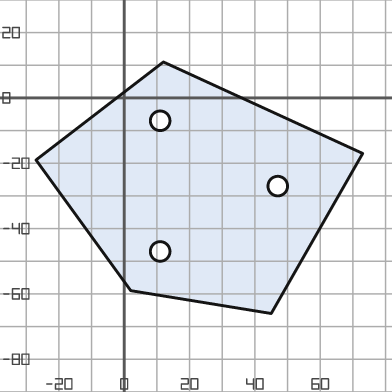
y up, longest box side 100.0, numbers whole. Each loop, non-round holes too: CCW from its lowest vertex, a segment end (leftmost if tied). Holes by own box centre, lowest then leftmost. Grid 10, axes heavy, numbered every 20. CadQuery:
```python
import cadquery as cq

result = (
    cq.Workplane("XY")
    .moveTo(45.0, -66.0)
    .lineTo(73.0, -17.0)
    .lineTo(12.0, 11.0)
    .lineTo(-27.0, -19.0)
    .lineTo(2.0, -59.0)
    .close()
    .moveTo(11.0, -47.0)
    .circle(3.0)
    .moveTo(47.0, -27.0)
    .circle(3.0)
    .moveTo(11.0, -7.0)
    .circle(3.0)
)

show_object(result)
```